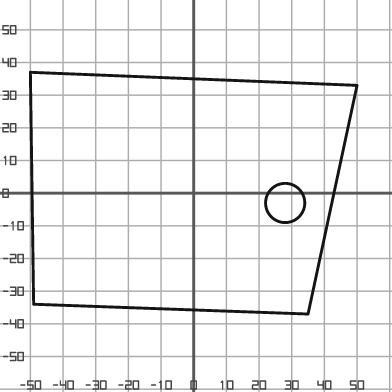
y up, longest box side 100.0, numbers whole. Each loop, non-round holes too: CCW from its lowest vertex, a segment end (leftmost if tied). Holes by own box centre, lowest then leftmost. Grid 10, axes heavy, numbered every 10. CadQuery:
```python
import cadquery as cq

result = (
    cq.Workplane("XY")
    .moveTo(35.0, -37.0)
    .lineTo(50.0, 33.0)
    .lineTo(-50.0, 37.0)
    .lineTo(-49.0, -34.0)
    .close()
    .moveTo(28.0, -3.0)
    .circle(6.0)
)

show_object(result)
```